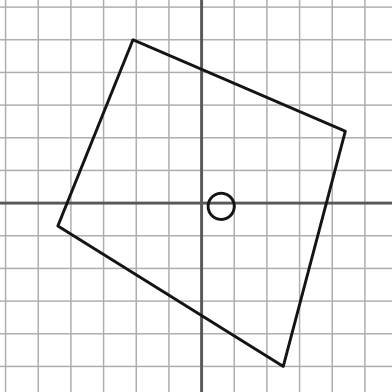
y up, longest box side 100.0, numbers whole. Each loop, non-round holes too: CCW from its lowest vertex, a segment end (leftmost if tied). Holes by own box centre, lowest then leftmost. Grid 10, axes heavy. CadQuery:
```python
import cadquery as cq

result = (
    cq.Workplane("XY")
    .moveTo(25.0, -50.0)
    .lineTo(44.0, 22.0)
    .lineTo(-21.0, 50.0)
    .lineTo(-44.0, -7.0)
    .close()
    .moveTo(6.0, -1.0)
    .circle(4.0)
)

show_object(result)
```